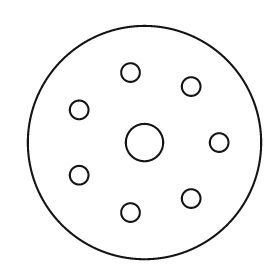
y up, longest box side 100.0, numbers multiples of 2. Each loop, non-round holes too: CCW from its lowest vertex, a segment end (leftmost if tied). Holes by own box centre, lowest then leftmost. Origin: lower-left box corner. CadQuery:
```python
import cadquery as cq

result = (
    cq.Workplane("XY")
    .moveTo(50.0, 50.0)
    .circle(50.0)
    .moveTo(44.0, 20.0)
    .circle(4.0)
    .moveTo(70.0, 26.0)
    .circle(4.0)
    .moveTo(22.0, 36.0)
    .circle(4.0)
    .moveTo(50.0, 50.0)
    .circle(8.0)
    .moveTo(82.0, 50.0)
    .circle(4.0)
    .moveTo(22.0, 64.0)
    .circle(4.0)
    .moveTo(70.0, 74.0)
    .circle(4.0)
    .moveTo(44.0, 80.0)
    .circle(4.0)
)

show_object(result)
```